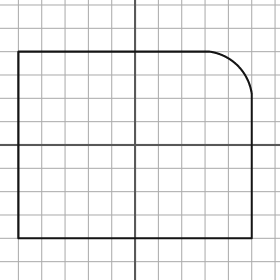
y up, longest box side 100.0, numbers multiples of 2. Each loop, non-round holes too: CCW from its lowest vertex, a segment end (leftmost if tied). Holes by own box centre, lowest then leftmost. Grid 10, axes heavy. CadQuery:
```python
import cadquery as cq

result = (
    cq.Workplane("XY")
    .moveTo(-50.0, -40.0)
    .lineTo(50.0, -40.0)
    .lineTo(50.0, 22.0)
    .threePointArc((44.0, 34.0), (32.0, 40.0))
    .lineTo(-50.0, 40.0)
    .close()
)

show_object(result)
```